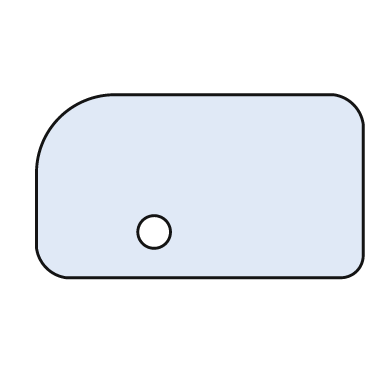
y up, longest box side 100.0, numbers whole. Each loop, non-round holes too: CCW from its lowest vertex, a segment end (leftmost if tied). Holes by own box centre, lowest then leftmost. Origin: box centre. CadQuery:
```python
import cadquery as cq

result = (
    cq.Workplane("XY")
    .moveTo(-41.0, -28.0)
    .lineTo(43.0, -28.0)
    .threePointArc((48.0, -26.0), (50.0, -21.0))
    .lineTo(50.0, 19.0)
    .threePointArc((47.0, 25.0), (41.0, 28.0))
    .lineTo(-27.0, 28.0)
    .threePointArc((-43.0, 21.0), (-50.0, 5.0))
    .lineTo(-50.0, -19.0)
    .threePointArc((-47.0, -25.0), (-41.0, -28.0))
    .close()
    .moveTo(-14.0, -14.0)
    .circle(5.0)
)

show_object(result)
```